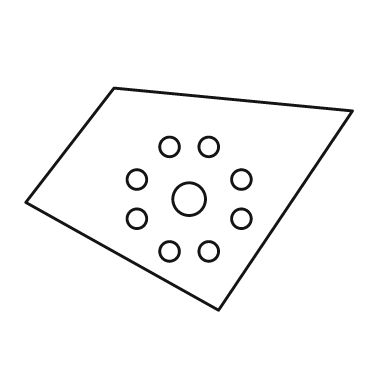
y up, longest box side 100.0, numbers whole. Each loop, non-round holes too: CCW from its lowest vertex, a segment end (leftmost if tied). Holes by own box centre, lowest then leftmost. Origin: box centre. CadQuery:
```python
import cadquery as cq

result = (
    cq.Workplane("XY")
    .moveTo(9.0, -34.0)
    .lineTo(50.0, 27.0)
    .lineTo(-23.0, 34.0)
    .lineTo(-50.0, -1.0)
    .close()
    .moveTo(-6.0, -16.0)
    .circle(3.0)
    .moveTo(6.0, -16.0)
    .circle(3.0)
    .moveTo(-16.0, -6.0)
    .circle(3.0)
    .moveTo(16.0, -6.0)
    .circle(3.0)
    .moveTo(0.0, 0.0)
    .circle(5.0)
    .moveTo(-16.0, 6.0)
    .circle(3.0)
    .moveTo(16.0, 6.0)
    .circle(3.0)
    .moveTo(-6.0, 16.0)
    .circle(3.0)
    .moveTo(6.0, 16.0)
    .circle(3.0)
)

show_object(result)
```